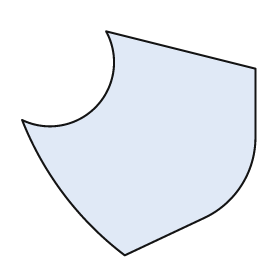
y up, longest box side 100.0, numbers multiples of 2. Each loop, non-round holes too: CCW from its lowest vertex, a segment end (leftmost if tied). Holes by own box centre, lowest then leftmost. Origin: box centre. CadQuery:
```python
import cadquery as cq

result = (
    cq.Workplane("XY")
    .moveTo(-6.0, -48.0)
    .lineTo(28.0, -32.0)
    .threePointArc((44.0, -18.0), (50.0, 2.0))
    .lineTo(50.0, 32.0)
    .lineTo(-14.0, 48.0)
    .threePointArc((-18.0, 16.0), (-50.0, 10.0))
    .threePointArc((-32.0, -22.0), (-6.0, -48.0))
    .close()
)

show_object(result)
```